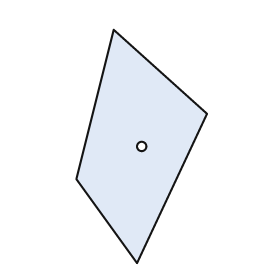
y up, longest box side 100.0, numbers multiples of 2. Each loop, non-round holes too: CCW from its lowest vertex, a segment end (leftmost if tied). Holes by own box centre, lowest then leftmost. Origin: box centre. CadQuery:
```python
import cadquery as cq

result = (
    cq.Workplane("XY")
    .moveTo(-2.0, -50.0)
    .lineTo(28.0, 14.0)
    .lineTo(-12.0, 50.0)
    .lineTo(-28.0, -14.0)
    .close()
    .moveTo(0.0, 0.0)
    .circle(2.0)
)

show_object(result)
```